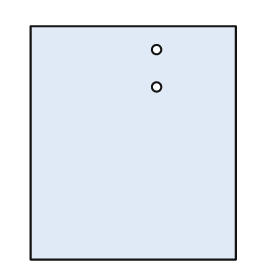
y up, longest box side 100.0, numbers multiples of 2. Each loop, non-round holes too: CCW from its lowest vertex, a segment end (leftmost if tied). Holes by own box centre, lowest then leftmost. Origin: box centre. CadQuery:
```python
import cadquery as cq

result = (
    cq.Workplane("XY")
    .moveTo(-44.0, -50.0)
    .lineTo(44.0, -50.0)
    .lineTo(44.0, 50.0)
    .lineTo(-44.0, 50.0)
    .close()
    .moveTo(10.0, 24.0)
    .circle(2.0)
    .moveTo(10.0, 40.0)
    .circle(2.0)
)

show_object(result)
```